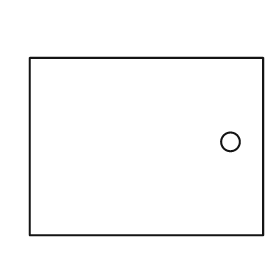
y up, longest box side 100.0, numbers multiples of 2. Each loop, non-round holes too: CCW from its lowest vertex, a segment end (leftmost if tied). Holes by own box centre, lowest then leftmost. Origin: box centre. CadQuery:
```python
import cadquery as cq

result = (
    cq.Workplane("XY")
    .moveTo(-50.0, -38.0)
    .lineTo(50.0, -38.0)
    .lineTo(50.0, 38.0)
    .lineTo(-50.0, 38.0)
    .close()
    .moveTo(36.0, 2.0)
    .circle(4.0)
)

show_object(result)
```